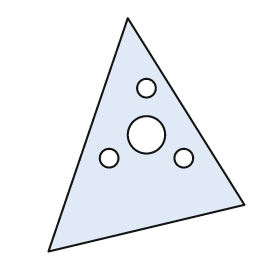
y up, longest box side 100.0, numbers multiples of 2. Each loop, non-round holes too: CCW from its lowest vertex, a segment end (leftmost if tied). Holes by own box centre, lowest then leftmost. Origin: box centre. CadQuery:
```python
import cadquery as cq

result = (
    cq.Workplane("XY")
    .moveTo(-42.0, -50.0)
    .lineTo(42.0, -30.0)
    .lineTo(-8.0, 50.0)
    .close()
    .moveTo(-16.0, -10.0)
    .circle(4.0)
    .moveTo(16.0, -10.0)
    .circle(4.0)
    .moveTo(0.0, 0.0)
    .circle(8.0)
    .moveTo(0.0, 20.0)
    .circle(4.0)
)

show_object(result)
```